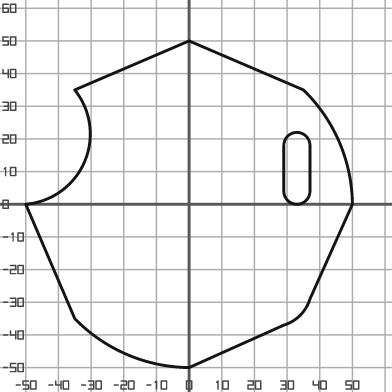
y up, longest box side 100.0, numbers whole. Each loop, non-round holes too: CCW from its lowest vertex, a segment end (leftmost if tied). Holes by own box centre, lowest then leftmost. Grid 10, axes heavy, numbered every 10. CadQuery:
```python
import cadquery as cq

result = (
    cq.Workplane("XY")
    .moveTo(0.0, -50.0)
    .lineTo(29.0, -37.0)
    .threePointArc((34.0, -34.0), (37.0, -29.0))
    .lineTo(50.0, 0.0)
    .threePointArc((46.0, 19.0), (35.0, 35.0))
    .lineTo(0.0, 50.0)
    .lineTo(-35.0, 35.0)
    .threePointArc((-32.0, 13.0), (-50.0, 0.0))
    .lineTo(-35.0, -35.0)
    .threePointArc((-19.0, -46.0), (0.0, -50.0))
    .close()
    .moveTo(29.0, 4.0)
    .threePointArc((33.0, 0.0), (37.0, 4.0))
    .lineTo(37.0, 18.0)
    .threePointArc((33.0, 22.0), (29.0, 18.0))
    .close()
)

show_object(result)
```